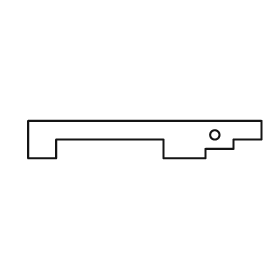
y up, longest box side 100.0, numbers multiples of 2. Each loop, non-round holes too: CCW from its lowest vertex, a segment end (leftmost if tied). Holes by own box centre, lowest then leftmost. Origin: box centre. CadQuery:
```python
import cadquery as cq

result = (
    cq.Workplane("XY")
    .moveTo(-50.0, -8.0)
    .lineTo(-38.0, -8.0)
    .lineTo(-38.0, 0.0)
    .lineTo(8.0, 0.0)
    .lineTo(8.0, -8.0)
    .lineTo(26.0, -8.0)
    .lineTo(26.0, -4.0)
    .lineTo(38.0, -4.0)
    .lineTo(38.0, 0.0)
    .lineTo(50.0, 0.0)
    .lineTo(50.0, 8.0)
    .lineTo(-50.0, 8.0)
    .close()
    .moveTo(30.0, 2.0)
    .circle(2.0)
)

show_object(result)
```